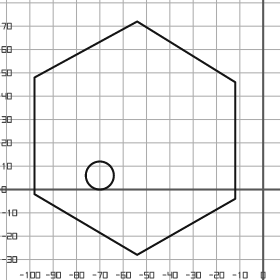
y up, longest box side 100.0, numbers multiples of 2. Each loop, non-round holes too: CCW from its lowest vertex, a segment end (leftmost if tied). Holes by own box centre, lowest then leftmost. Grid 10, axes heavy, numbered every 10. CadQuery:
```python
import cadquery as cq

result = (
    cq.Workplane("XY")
    .moveTo(-54.0, -28.0)
    .lineTo(-12.0, -4.0)
    .lineTo(-12.0, 46.0)
    .lineTo(-54.0, 72.0)
    .lineTo(-98.0, 48.0)
    .lineTo(-98.0, -2.0)
    .close()
    .moveTo(-70.0, 6.0)
    .circle(6.0)
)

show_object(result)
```